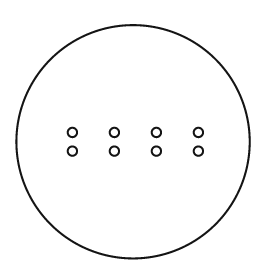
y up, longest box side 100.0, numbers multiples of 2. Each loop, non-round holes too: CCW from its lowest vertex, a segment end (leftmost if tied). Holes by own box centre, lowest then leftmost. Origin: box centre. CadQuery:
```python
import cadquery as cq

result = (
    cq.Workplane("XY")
    .moveTo(0.0, 0.0)
    .circle(50.0)
    .moveTo(-26.0, -4.0)
    .circle(2.0)
    .moveTo(-8.0, -4.0)
    .circle(2.0)
    .moveTo(10.0, -4.0)
    .circle(2.0)
    .moveTo(28.0, -4.0)
    .circle(2.0)
    .moveTo(-26.0, 4.0)
    .circle(2.0)
    .moveTo(-8.0, 4.0)
    .circle(2.0)
    .moveTo(10.0, 4.0)
    .circle(2.0)
    .moveTo(28.0, 4.0)
    .circle(2.0)
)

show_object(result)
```